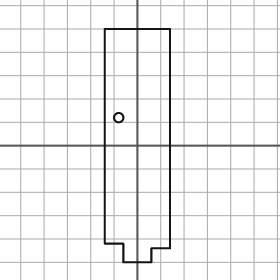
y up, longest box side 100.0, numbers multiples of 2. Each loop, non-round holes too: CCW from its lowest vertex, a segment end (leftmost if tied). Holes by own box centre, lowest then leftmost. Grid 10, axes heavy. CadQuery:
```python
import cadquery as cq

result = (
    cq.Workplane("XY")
    .moveTo(-6.0, -50.0)
    .lineTo(6.0, -50.0)
    .lineTo(6.0, -44.0)
    .lineTo(14.0, -44.0)
    .lineTo(14.0, 50.0)
    .lineTo(-14.0, 50.0)
    .lineTo(-14.0, -42.0)
    .lineTo(-6.0, -42.0)
    .close()
    .moveTo(-8.0, 12.0)
    .circle(2.0)
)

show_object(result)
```